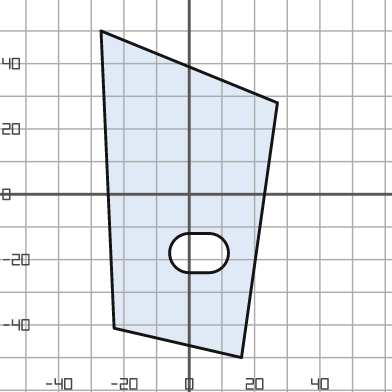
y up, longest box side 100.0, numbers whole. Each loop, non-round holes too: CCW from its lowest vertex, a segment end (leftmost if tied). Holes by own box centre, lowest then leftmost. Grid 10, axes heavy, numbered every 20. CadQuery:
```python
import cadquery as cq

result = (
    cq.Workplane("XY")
    .moveTo(16.0, -50.0)
    .lineTo(27.0, 28.0)
    .lineTo(-27.0, 50.0)
    .lineTo(-23.0, -41.0)
    .close()
    .moveTo(0.0, -24.0)
    .lineTo(6.0, -24.0)
    .threePointArc((12.0, -18.0), (6.0, -12.0))
    .lineTo(0.0, -12.0)
    .threePointArc((-6.0, -18.0), (0.0, -24.0))
    .close()
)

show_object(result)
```